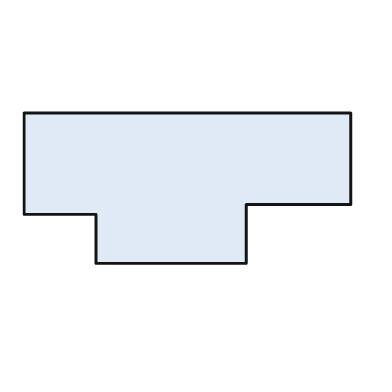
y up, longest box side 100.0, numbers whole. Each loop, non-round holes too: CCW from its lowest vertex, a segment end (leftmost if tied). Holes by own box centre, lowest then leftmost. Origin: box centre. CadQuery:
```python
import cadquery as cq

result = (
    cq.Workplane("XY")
    .moveTo(-28.0, -23.0)
    .lineTo(18.0, -23.0)
    .lineTo(18.0, -5.0)
    .lineTo(50.0, -5.0)
    .lineTo(50.0, 23.0)
    .lineTo(-50.0, 23.0)
    .lineTo(-50.0, -8.0)
    .lineTo(-28.0, -8.0)
    .close()
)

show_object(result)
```